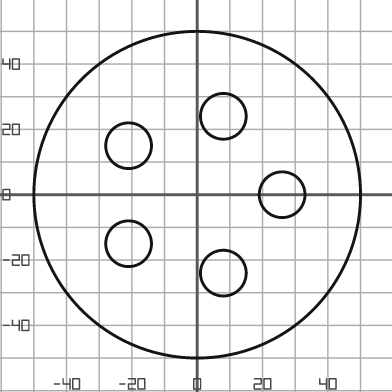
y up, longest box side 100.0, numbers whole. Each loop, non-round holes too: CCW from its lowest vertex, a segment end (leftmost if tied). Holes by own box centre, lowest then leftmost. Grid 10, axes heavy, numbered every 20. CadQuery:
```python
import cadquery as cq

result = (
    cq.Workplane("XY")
    .moveTo(0.0, 0.0)
    .circle(50.0)
    .moveTo(8.0, -24.0)
    .circle(7.0)
    .moveTo(-21.0, -15.0)
    .circle(7.0)
    .moveTo(26.0, 0.0)
    .circle(7.0)
    .moveTo(-21.0, 15.0)
    .circle(7.0)
    .moveTo(8.0, 24.0)
    .circle(7.0)
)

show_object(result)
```